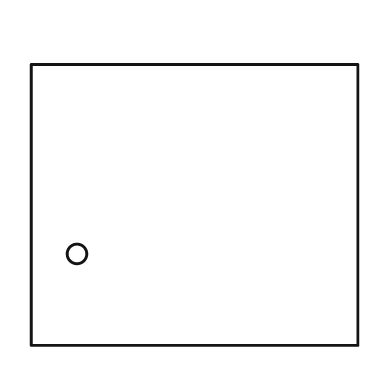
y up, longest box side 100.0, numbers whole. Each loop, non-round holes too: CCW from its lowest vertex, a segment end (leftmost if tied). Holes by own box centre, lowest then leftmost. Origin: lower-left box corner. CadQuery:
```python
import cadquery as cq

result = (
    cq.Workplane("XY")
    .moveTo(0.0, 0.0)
    .lineTo(100.0, 0.0)
    .lineTo(100.0, 86.0)
    .lineTo(0.0, 86.0)
    .close()
    .moveTo(14.0, 28.0)
    .circle(3.0)
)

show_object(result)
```